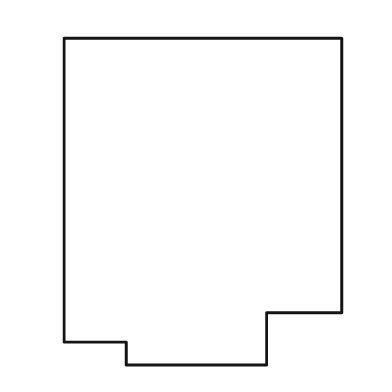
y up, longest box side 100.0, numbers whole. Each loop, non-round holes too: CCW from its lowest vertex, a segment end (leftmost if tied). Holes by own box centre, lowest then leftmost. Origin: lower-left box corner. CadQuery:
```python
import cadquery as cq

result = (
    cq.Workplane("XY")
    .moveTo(19.0, 0.0)
    .lineTo(62.0, 0.0)
    .lineTo(62.0, 16.0)
    .lineTo(85.0, 16.0)
    .lineTo(85.0, 100.0)
    .lineTo(0.0, 100.0)
    .lineTo(0.0, 7.0)
    .lineTo(19.0, 7.0)
    .close()
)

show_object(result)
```